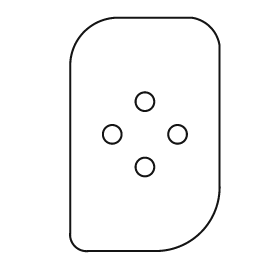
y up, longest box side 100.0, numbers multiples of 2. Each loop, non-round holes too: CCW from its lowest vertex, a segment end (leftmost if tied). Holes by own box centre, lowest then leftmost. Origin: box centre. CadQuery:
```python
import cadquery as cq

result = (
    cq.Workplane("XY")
    .moveTo(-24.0, -50.0)
    .lineTo(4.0, -50.0)
    .threePointArc((24.0, -42.0), (32.0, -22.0))
    .lineTo(32.0, 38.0)
    .threePointArc((28.0, 46.0), (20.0, 50.0))
    .lineTo(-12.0, 50.0)
    .threePointArc((-26.0, 44.0), (-32.0, 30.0))
    .lineTo(-32.0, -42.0)
    .threePointArc((-30.0, -48.0), (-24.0, -50.0))
    .close()
    .moveTo(0.0, -14.0)
    .circle(4.0)
    .moveTo(-14.0, 0.0)
    .circle(4.0)
    .moveTo(14.0, 0.0)
    .circle(4.0)
    .moveTo(0.0, 14.0)
    .circle(4.0)
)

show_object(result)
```